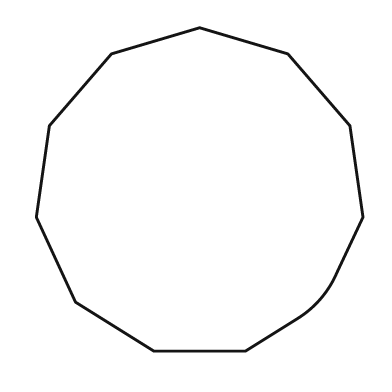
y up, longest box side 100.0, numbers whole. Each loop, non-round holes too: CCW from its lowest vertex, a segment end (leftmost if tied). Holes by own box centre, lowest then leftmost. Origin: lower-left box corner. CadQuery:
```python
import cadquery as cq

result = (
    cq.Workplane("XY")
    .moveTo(36.0, 0.0)
    .lineTo(64.0, 0.0)
    .lineTo(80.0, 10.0)
    .threePointArc((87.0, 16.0), (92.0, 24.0))
    .lineTo(100.0, 41.0)
    .lineTo(96.0, 69.0)
    .lineTo(77.0, 91.0)
    .lineTo(50.0, 99.0)
    .lineTo(23.0, 91.0)
    .lineTo(4.0, 69.0)
    .lineTo(0.0, 41.0)
    .lineTo(12.0, 15.0)
    .close()
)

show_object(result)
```